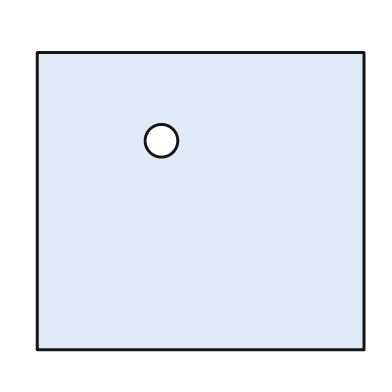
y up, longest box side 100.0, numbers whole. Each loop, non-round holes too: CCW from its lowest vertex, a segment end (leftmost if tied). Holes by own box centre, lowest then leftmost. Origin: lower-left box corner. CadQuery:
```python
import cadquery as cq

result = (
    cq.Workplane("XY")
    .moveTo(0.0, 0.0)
    .lineTo(100.0, 0.0)
    .lineTo(100.0, 91.0)
    .lineTo(0.0, 91.0)
    .close()
    .moveTo(38.0, 64.0)
    .circle(5.0)
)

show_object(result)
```